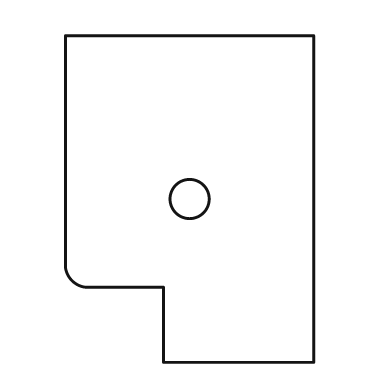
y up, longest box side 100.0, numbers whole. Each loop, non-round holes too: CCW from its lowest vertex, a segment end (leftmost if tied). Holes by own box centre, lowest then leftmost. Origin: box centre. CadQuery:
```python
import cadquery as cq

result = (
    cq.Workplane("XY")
    .moveTo(-8.0, -50.0)
    .lineTo(38.0, -50.0)
    .lineTo(38.0, 50.0)
    .lineTo(-38.0, 50.0)
    .lineTo(-38.0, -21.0)
    .threePointArc((-36.0, -25.0), (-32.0, -27.0))
    .lineTo(-8.0, -27.0)
    .close()
    .moveTo(0.0, 0.0)
    .circle(6.0)
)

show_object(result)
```